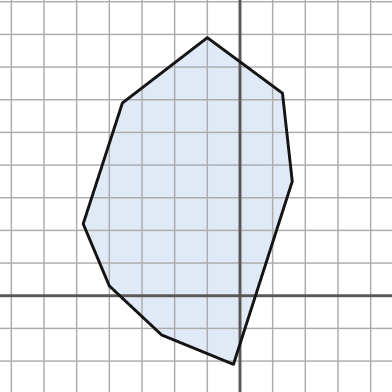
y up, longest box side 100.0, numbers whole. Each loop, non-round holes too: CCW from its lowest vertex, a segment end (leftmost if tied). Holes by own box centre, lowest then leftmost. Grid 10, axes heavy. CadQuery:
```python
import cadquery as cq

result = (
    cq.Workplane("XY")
    .moveTo(-2.0, -21.0)
    .lineTo(16.0, 35.0)
    .lineTo(13.0, 62.0)
    .lineTo(-10.0, 79.0)
    .lineTo(-36.0, 59.0)
    .lineTo(-48.0, 22.0)
    .lineTo(-40.0, 3.0)
    .lineTo(-24.0, -12.0)
    .close()
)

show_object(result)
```